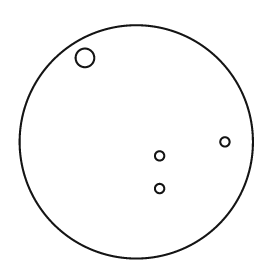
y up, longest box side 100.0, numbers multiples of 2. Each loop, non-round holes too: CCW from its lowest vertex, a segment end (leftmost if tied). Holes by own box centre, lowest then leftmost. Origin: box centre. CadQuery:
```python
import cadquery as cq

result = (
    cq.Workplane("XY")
    .moveTo(0.0, 0.0)
    .circle(50.0)
    .moveTo(10.0, -20.0)
    .circle(2.0)
    .moveTo(10.0, -6.0)
    .circle(2.0)
    .moveTo(38.0, 0.0)
    .circle(2.0)
    .moveTo(-22.0, 36.0)
    .circle(4.0)
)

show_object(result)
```